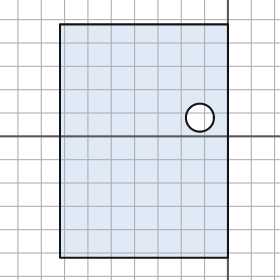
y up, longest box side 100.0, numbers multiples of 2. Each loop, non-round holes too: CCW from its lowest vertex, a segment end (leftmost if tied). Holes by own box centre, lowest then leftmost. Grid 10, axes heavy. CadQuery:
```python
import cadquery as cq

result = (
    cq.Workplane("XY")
    .moveTo(-72.0, -52.0)
    .lineTo(0.0, -52.0)
    .lineTo(0.0, 48.0)
    .lineTo(-72.0, 48.0)
    .close()
    .moveTo(-12.0, 8.0)
    .circle(6.0)
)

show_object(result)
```